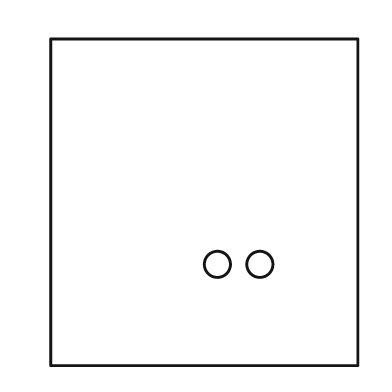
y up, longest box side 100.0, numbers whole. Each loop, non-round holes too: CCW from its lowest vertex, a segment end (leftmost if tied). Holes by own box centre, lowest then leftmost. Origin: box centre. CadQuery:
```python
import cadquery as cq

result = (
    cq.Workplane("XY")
    .moveTo(-47.0, -50.0)
    .lineTo(47.0, -50.0)
    .lineTo(47.0, 50.0)
    .lineTo(-47.0, 50.0)
    .close()
    .moveTo(4.0, -19.0)
    .circle(4.0)
    .moveTo(17.0, -19.0)
    .circle(4.0)
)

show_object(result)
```